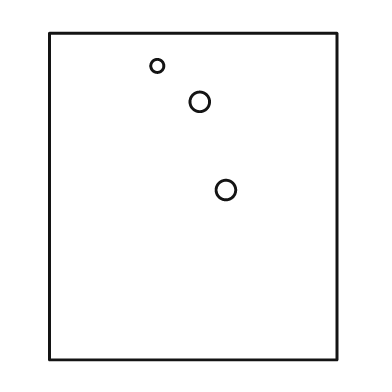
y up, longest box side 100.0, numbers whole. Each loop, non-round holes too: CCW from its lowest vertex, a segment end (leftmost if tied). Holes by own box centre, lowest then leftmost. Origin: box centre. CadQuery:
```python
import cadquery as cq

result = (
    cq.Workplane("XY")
    .moveTo(-44.0, -50.0)
    .lineTo(44.0, -50.0)
    .lineTo(44.0, 50.0)
    .lineTo(-44.0, 50.0)
    .close()
    .moveTo(10.0, 2.0)
    .circle(3.0)
    .moveTo(2.0, 29.0)
    .circle(3.0)
    .moveTo(-11.0, 40.0)
    .circle(2.0)
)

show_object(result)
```